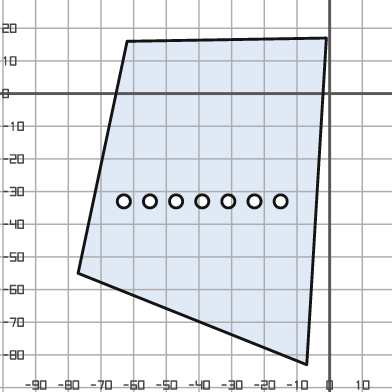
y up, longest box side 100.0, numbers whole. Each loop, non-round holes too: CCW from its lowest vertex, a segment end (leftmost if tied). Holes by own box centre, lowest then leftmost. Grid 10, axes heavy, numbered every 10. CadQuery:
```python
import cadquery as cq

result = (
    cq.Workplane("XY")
    .moveTo(-7.0, -83.0)
    .lineTo(-1.0, 17.0)
    .lineTo(-62.0, 16.0)
    .lineTo(-77.0, -55.0)
    .close()
    .moveTo(-63.0, -33.0)
    .circle(2.0)
    .moveTo(-55.0, -33.0)
    .circle(2.0)
    .moveTo(-47.0, -33.0)
    .circle(2.0)
    .moveTo(-39.0, -33.0)
    .circle(2.0)
    .moveTo(-31.0, -33.0)
    .circle(2.0)
    .moveTo(-23.0, -33.0)
    .circle(2.0)
    .moveTo(-15.0, -33.0)
    .circle(2.0)
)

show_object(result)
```